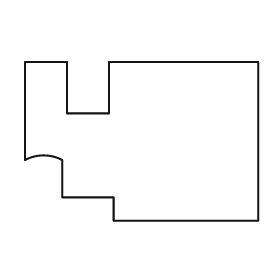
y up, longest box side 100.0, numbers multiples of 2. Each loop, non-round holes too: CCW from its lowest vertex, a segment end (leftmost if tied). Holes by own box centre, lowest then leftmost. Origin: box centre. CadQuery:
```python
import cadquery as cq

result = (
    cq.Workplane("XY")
    .moveTo(-12.0, -34.0)
    .lineTo(50.0, -34.0)
    .lineTo(50.0, 34.0)
    .lineTo(-14.0, 34.0)
    .lineTo(-14.0, 12.0)
    .lineTo(-32.0, 12.0)
    .lineTo(-32.0, 34.0)
    .lineTo(-50.0, 34.0)
    .lineTo(-50.0, -8.0)
    .threePointArc((-42.0, -6.0), (-34.0, -8.0))
    .lineTo(-34.0, -24.0)
    .lineTo(-12.0, -24.0)
    .close()
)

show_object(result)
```